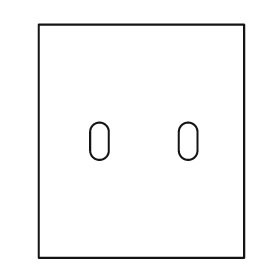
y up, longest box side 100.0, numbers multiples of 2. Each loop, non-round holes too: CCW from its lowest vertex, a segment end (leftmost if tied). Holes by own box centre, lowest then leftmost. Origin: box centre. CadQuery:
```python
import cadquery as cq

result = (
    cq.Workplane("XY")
    .moveTo(-44.0, -50.0)
    .lineTo(44.0, -50.0)
    .lineTo(44.0, 50.0)
    .lineTo(-44.0, 50.0)
    .close()
    .moveTo(-22.0, -4.0)
    .threePointArc((-18.0, -8.0), (-14.0, -4.0))
    .lineTo(-14.0, 4.0)
    .threePointArc((-18.0, 8.0), (-22.0, 4.0))
    .close()
    .moveTo(16.0, -4.0)
    .threePointArc((20.0, -8.0), (24.0, -4.0))
    .lineTo(24.0, 4.0)
    .threePointArc((20.0, 8.0), (16.0, 4.0))
    .close()
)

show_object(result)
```